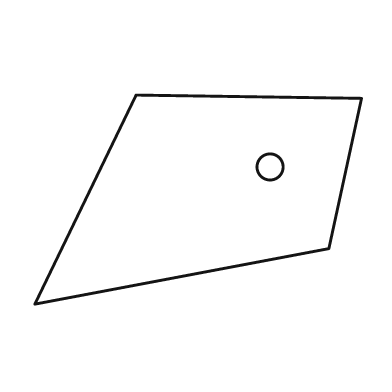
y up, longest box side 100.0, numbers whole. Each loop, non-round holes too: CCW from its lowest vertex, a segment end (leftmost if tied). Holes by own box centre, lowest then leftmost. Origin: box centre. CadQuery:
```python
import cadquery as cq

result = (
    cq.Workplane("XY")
    .moveTo(-50.0, -32.0)
    .lineTo(40.0, -15.0)
    .lineTo(50.0, 31.0)
    .lineTo(-19.0, 32.0)
    .close()
    .moveTo(22.0, 10.0)
    .circle(4.0)
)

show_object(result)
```